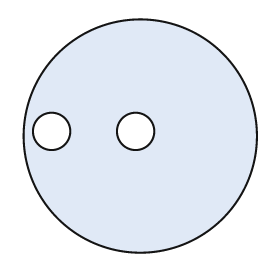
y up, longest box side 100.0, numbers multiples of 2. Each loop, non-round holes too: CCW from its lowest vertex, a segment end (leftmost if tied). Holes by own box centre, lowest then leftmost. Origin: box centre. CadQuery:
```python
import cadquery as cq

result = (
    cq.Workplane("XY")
    .moveTo(0.0, 0.0)
    .circle(50.0)
    .moveTo(-38.0, 2.0)
    .circle(8.0)
    .moveTo(-2.0, 2.0)
    .circle(8.0)
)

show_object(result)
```